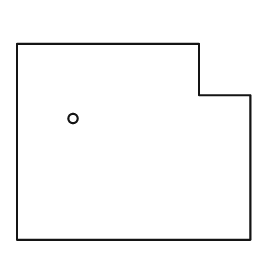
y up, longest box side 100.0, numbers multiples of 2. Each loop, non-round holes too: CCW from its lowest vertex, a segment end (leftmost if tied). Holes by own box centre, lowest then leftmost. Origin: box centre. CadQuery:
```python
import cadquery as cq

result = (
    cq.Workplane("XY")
    .moveTo(-50.0, -42.0)
    .lineTo(50.0, -42.0)
    .lineTo(50.0, 20.0)
    .lineTo(28.0, 20.0)
    .lineTo(28.0, 42.0)
    .lineTo(-50.0, 42.0)
    .close()
    .moveTo(-26.0, 10.0)
    .circle(2.0)
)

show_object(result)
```